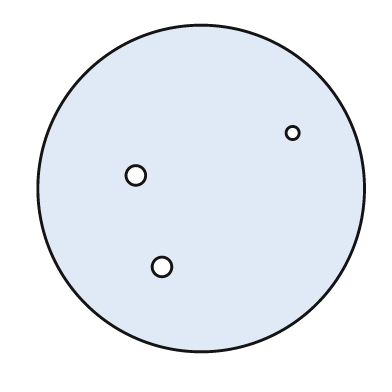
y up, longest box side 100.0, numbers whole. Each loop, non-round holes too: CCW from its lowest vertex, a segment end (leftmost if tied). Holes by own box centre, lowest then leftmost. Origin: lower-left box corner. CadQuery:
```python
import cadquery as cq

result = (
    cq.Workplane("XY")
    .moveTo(50.0, 50.0)
    .circle(50.0)
    .moveTo(38.0, 26.0)
    .circle(3.0)
    .moveTo(30.0, 54.0)
    .circle(3.0)
    .moveTo(78.0, 67.0)
    .circle(2.0)
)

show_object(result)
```